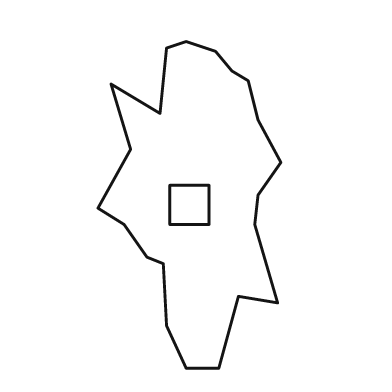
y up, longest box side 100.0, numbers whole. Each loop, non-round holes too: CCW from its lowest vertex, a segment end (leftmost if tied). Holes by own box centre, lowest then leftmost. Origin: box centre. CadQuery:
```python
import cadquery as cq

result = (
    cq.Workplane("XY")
    .moveTo(-1.0, -50.0)
    .lineTo(9.0, -50.0)
    .lineTo(15.0, -28.0)
    .lineTo(27.0, -30.0)
    .lineTo(20.0, -6.0)
    .lineTo(21.0, 3.0)
    .lineTo(28.0, 13.0)
    .lineTo(21.0, 26.0)
    .lineTo(18.0, 38.0)
    .lineTo(13.0, 41.0)
    .lineTo(8.0, 47.0)
    .lineTo(-1.0, 50.0)
    .lineTo(-7.0, 48.0)
    .lineTo(-9.0, 28.0)
    .lineTo(-24.0, 37.0)
    .lineTo(-18.0, 17.0)
    .lineTo(-28.0, -1.0)
    .lineTo(-20.0, -6.0)
    .lineTo(-13.0, -16.0)
    .lineTo(-8.0, -18.0)
    .lineTo(-7.0, -37.0)
    .close()
    .moveTo(-6.0, -6.0)
    .lineTo(6.0, -6.0)
    .lineTo(6.0, 6.0)
    .lineTo(-6.0, 6.0)
    .close()
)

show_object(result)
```